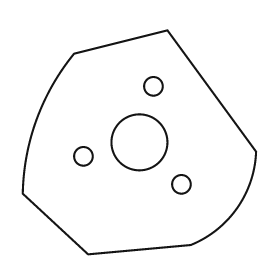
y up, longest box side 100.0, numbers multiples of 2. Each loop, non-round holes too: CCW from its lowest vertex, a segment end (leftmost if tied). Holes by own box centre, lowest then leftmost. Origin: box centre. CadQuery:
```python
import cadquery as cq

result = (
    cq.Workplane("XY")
    .moveTo(-22.0, -48.0)
    .lineTo(22.0, -44.0)
    .threePointArc((42.0, -28.0), (50.0, -4.0))
    .lineTo(12.0, 48.0)
    .lineTo(-28.0, 38.0)
    .threePointArc((-44.0, 10.0), (-50.0, -22.0))
    .close()
    .moveTo(18.0, -18.0)
    .circle(4.0)
    .moveTo(-24.0, -6.0)
    .circle(4.0)
    .moveTo(0.0, 0.0)
    .circle(12.0)
    .moveTo(6.0, 24.0)
    .circle(4.0)
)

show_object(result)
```